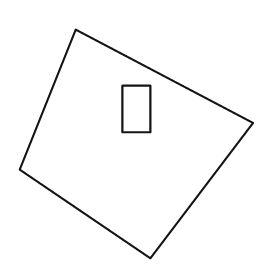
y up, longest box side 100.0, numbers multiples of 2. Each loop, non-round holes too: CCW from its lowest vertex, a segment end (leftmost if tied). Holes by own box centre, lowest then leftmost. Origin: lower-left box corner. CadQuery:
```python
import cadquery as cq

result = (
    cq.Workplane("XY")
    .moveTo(56.0, 0.0)
    .lineTo(100.0, 58.0)
    .lineTo(24.0, 98.0)
    .lineTo(0.0, 38.0)
    .close()
    .moveTo(44.0, 54.0)
    .lineTo(56.0, 54.0)
    .lineTo(56.0, 74.0)
    .lineTo(44.0, 74.0)
    .close()
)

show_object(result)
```